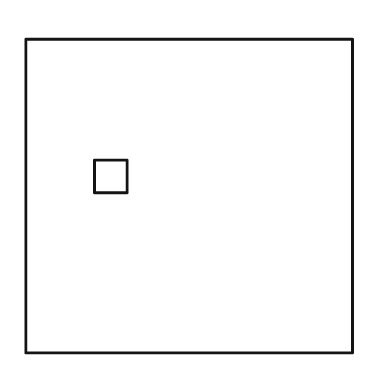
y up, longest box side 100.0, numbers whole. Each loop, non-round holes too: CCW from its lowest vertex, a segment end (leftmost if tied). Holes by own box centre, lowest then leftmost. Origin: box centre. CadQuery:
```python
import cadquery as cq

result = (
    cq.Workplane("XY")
    .moveTo(-50.0, -48.0)
    .lineTo(50.0, -48.0)
    .lineTo(50.0, 48.0)
    .lineTo(-50.0, 48.0)
    .close()
    .moveTo(-29.0, 1.0)
    .lineTo(-19.0, 1.0)
    .lineTo(-19.0, 11.0)
    .lineTo(-29.0, 11.0)
    .close()
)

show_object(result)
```